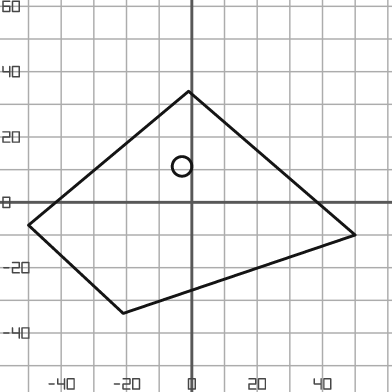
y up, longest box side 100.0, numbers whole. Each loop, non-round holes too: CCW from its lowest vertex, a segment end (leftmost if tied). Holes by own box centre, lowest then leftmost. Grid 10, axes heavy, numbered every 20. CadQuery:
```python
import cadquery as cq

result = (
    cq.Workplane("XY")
    .moveTo(-21.0, -34.0)
    .lineTo(50.0, -10.0)
    .lineTo(-1.0, 34.0)
    .lineTo(-50.0, -7.0)
    .close()
    .moveTo(-3.0, 11.0)
    .circle(3.0)
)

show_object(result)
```